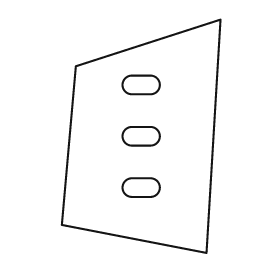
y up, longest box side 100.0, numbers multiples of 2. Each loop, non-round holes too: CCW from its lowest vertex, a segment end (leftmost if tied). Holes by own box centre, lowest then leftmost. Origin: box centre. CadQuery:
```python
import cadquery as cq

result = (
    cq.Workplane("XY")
    .moveTo(28.0, -50.0)
    .lineTo(34.0, 50.0)
    .lineTo(-28.0, 30.0)
    .lineTo(-34.0, -38.0)
    .close()
    .moveTo(-4.0, -26.0)
    .lineTo(4.0, -26.0)
    .threePointArc((8.0, -22.0), (4.0, -18.0))
    .lineTo(-4.0, -18.0)
    .threePointArc((-8.0, -22.0), (-4.0, -26.0))
    .close()
    .moveTo(-4.0, -4.0)
    .lineTo(4.0, -4.0)
    .threePointArc((8.0, 0.0), (4.0, 4.0))
    .lineTo(-4.0, 4.0)
    .threePointArc((-8.0, 0.0), (-4.0, -4.0))
    .close()
    .moveTo(-4.0, 18.0)
    .lineTo(4.0, 18.0)
    .threePointArc((8.0, 22.0), (4.0, 26.0))
    .lineTo(-4.0, 26.0)
    .threePointArc((-8.0, 22.0), (-4.0, 18.0))
    .close()
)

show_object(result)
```